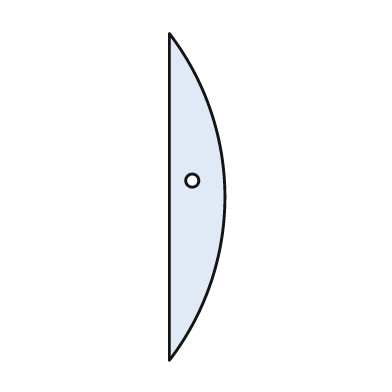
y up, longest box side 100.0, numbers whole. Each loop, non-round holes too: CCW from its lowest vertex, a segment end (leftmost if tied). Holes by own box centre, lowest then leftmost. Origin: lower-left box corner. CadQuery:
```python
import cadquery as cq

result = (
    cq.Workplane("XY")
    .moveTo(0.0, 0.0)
    .threePointArc((17.0, 50.0), (0.0, 100.0))
    .close()
    .moveTo(7.0, 55.0)
    .circle(2.0)
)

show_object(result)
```